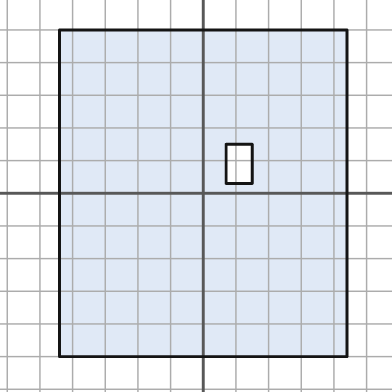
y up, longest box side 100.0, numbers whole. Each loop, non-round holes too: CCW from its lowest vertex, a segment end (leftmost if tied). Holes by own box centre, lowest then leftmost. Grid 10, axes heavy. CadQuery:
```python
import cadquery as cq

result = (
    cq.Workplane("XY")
    .moveTo(-44.0, -50.0)
    .lineTo(44.0, -50.0)
    .lineTo(44.0, 50.0)
    .lineTo(-44.0, 50.0)
    .close()
    .moveTo(7.0, 3.0)
    .lineTo(15.0, 3.0)
    .lineTo(15.0, 15.0)
    .lineTo(7.0, 15.0)
    .close()
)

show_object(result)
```